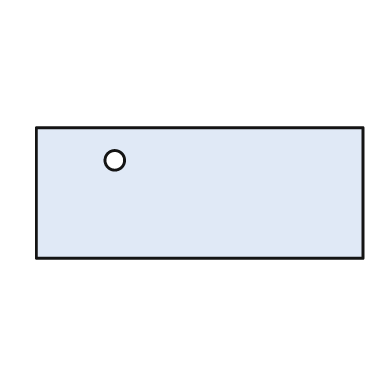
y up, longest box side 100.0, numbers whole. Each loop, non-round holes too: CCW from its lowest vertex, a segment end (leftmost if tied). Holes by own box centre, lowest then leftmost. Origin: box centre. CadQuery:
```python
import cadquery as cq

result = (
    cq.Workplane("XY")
    .moveTo(-50.0, -20.0)
    .lineTo(50.0, -20.0)
    .lineTo(50.0, 20.0)
    .lineTo(-50.0, 20.0)
    .close()
    .moveTo(-26.0, 10.0)
    .circle(3.0)
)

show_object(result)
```